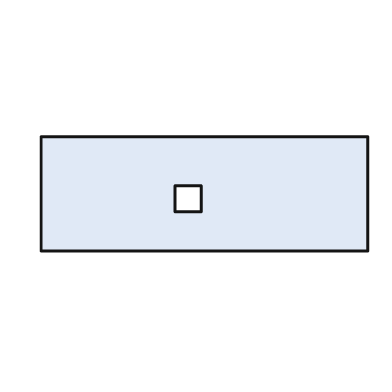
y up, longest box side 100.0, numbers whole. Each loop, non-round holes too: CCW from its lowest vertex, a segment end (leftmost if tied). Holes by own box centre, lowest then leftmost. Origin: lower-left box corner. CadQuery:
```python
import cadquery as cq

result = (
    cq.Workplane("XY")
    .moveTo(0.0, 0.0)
    .lineTo(100.0, 0.0)
    .lineTo(100.0, 35.0)
    .lineTo(0.0, 35.0)
    .close()
    .moveTo(41.0, 12.0)
    .lineTo(49.0, 12.0)
    .lineTo(49.0, 20.0)
    .lineTo(41.0, 20.0)
    .close()
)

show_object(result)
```